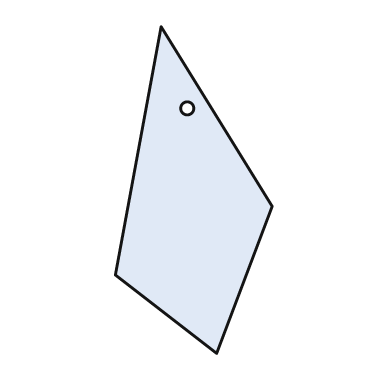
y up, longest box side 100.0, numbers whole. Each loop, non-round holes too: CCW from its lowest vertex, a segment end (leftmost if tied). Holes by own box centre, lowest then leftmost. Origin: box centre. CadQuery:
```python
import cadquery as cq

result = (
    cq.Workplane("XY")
    .moveTo(7.0, -50.0)
    .lineTo(24.0, -5.0)
    .lineTo(-10.0, 50.0)
    .lineTo(-24.0, -26.0)
    .close()
    .moveTo(-2.0, 25.0)
    .circle(2.0)
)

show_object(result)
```